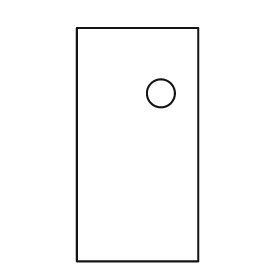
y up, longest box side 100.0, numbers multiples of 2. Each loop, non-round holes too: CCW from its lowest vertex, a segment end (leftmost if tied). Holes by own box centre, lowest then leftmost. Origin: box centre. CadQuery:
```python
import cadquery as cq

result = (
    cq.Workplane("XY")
    .moveTo(-26.0, -50.0)
    .lineTo(26.0, -50.0)
    .lineTo(26.0, 50.0)
    .lineTo(-26.0, 50.0)
    .close()
    .moveTo(10.0, 22.0)
    .circle(6.0)
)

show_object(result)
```